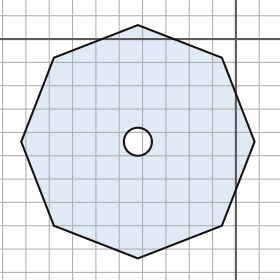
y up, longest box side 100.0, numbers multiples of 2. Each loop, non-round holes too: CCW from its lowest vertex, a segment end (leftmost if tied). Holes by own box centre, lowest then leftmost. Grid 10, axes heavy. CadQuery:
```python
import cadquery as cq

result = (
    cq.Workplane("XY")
    .moveTo(-42.0, -94.0)
    .lineTo(-6.0, -80.0)
    .lineTo(8.0, -44.0)
    .lineTo(-6.0, -8.0)
    .lineTo(-42.0, 6.0)
    .lineTo(-78.0, -8.0)
    .lineTo(-92.0, -44.0)
    .lineTo(-78.0, -80.0)
    .close()
    .moveTo(-42.0, -44.0)
    .circle(6.0)
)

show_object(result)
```